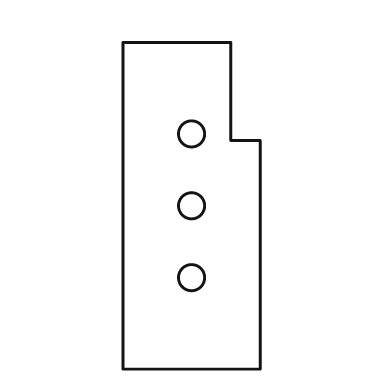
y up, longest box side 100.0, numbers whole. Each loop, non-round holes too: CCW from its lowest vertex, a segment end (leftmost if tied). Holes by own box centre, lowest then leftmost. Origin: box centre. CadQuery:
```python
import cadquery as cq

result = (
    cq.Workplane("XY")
    .moveTo(-21.0, -50.0)
    .lineTo(21.0, -50.0)
    .lineTo(21.0, 20.0)
    .lineTo(12.0, 20.0)
    .lineTo(12.0, 50.0)
    .lineTo(-21.0, 50.0)
    .close()
    .moveTo(0.0, -22.0)
    .circle(4.0)
    .moveTo(0.0, 0.0)
    .circle(4.0)
    .moveTo(0.0, 22.0)
    .circle(4.0)
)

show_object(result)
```